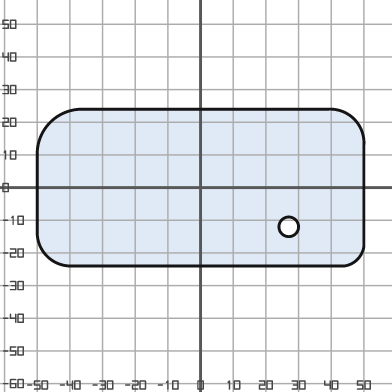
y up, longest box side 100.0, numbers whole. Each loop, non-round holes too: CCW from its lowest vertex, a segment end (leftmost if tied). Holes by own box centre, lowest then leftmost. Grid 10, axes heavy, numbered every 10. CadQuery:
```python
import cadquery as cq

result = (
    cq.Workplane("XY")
    .moveTo(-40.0, -24.0)
    .lineTo(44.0, -24.0)
    .threePointArc((48.0, -22.0), (50.0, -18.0))
    .lineTo(50.0, 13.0)
    .threePointArc((47.0, 21.0), (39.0, 24.0))
    .lineTo(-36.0, 24.0)
    .threePointArc((-46.0, 20.0), (-50.0, 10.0))
    .lineTo(-50.0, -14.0)
    .threePointArc((-47.0, -21.0), (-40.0, -24.0))
    .close()
    .moveTo(27.0, -12.0)
    .circle(3.0)
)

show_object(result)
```